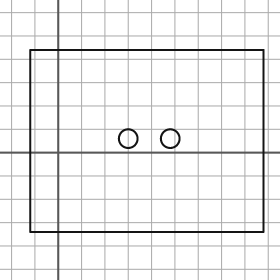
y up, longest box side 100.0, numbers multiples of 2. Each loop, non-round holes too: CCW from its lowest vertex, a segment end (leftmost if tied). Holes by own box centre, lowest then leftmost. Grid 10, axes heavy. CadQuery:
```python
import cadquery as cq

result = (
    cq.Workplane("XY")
    .moveTo(-12.0, -34.0)
    .lineTo(88.0, -34.0)
    .lineTo(88.0, 44.0)
    .lineTo(-12.0, 44.0)
    .close()
    .moveTo(30.0, 6.0)
    .circle(4.0)
    .moveTo(48.0, 6.0)
    .circle(4.0)
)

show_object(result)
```